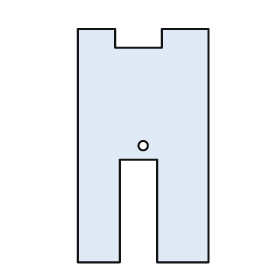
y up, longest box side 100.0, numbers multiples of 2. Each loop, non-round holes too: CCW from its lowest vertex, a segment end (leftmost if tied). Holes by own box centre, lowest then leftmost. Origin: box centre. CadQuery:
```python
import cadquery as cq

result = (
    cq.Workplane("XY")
    .moveTo(-28.0, -50.0)
    .lineTo(-10.0, -50.0)
    .lineTo(-10.0, -6.0)
    .lineTo(6.0, -6.0)
    .lineTo(6.0, -50.0)
    .lineTo(28.0, -50.0)
    .lineTo(28.0, 50.0)
    .lineTo(8.0, 50.0)
    .lineTo(8.0, 42.0)
    .lineTo(-12.0, 42.0)
    .lineTo(-12.0, 50.0)
    .lineTo(-28.0, 50.0)
    .close()
    .moveTo(0.0, 0.0)
    .circle(2.0)
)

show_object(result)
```